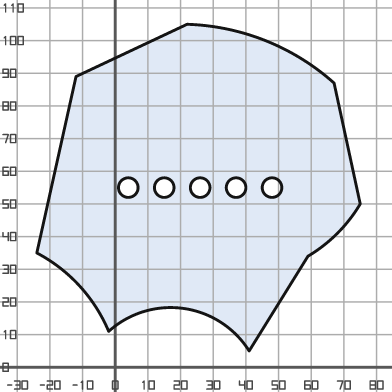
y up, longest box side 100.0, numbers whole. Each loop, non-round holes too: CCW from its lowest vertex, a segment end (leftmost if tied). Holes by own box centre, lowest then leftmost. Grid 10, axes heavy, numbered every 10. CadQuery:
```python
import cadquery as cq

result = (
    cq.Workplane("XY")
    .moveTo(41.0, 5.0)
    .lineTo(59.0, 34.0)
    .threePointArc((68.0, 41.0), (75.0, 50.0))
    .lineTo(67.0, 87.0)
    .threePointArc((46.0, 100.0), (22.0, 105.0))
    .lineTo(-12.0, 89.0)
    .lineTo(-24.0, 35.0)
    .threePointArc((-11.0, 25.0), (-2.0, 11.0))
    .threePointArc((21.0, 18.0), (41.0, 5.0))
    .close()
    .moveTo(4.0, 55.0)
    .circle(3.0)
    .moveTo(15.0, 55.0)
    .circle(3.0)
    .moveTo(26.0, 55.0)
    .circle(3.0)
    .moveTo(37.0, 55.0)
    .circle(3.0)
    .moveTo(48.0, 55.0)
    .circle(3.0)
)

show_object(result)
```